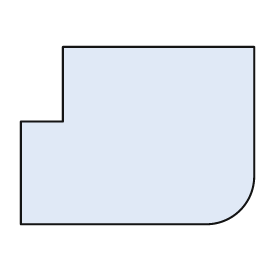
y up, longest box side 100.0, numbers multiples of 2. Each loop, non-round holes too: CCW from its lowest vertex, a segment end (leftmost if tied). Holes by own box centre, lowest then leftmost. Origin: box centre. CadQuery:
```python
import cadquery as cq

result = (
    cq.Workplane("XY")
    .moveTo(-50.0, -38.0)
    .lineTo(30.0, -38.0)
    .threePointArc((44.0, -32.0), (50.0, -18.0))
    .lineTo(50.0, 38.0)
    .lineTo(-32.0, 38.0)
    .lineTo(-32.0, 6.0)
    .lineTo(-50.0, 6.0)
    .close()
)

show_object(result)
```